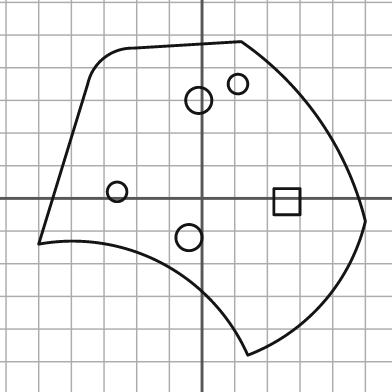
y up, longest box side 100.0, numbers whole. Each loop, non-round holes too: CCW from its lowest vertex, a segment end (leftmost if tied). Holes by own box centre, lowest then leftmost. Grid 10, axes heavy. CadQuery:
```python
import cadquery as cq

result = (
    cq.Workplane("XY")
    .moveTo(14.0, -48.0)
    .threePointArc((37.0, -32.0), (50.0, -7.0))
    .threePointArc((36.0, 24.0), (12.0, 48.0))
    .lineTo(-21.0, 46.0)
    .threePointArc((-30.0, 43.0), (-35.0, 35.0))
    .lineTo(-50.0, -14.0)
    .threePointArc((-12.0, -20.0), (14.0, -48.0))
    .close()
    .moveTo(-4.0, -12.0)
    .circle(4.0)
    .moveTo(22.0, -5.0)
    .lineTo(30.0, -5.0)
    .lineTo(30.0, 3.0)
    .lineTo(22.0, 3.0)
    .close()
    .moveTo(-26.0, 2.0)
    .circle(3.0)
    .moveTo(-1.0, 30.0)
    .circle(4.0)
    .moveTo(11.0, 35.0)
    .circle(3.0)
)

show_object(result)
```